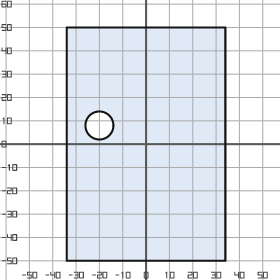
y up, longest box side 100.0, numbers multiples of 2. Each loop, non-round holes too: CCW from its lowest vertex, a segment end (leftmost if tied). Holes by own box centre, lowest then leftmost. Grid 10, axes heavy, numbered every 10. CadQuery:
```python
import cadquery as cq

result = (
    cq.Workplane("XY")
    .moveTo(-34.0, -50.0)
    .lineTo(34.0, -50.0)
    .lineTo(34.0, 50.0)
    .lineTo(-34.0, 50.0)
    .close()
    .moveTo(-20.0, 8.0)
    .circle(6.0)
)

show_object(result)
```